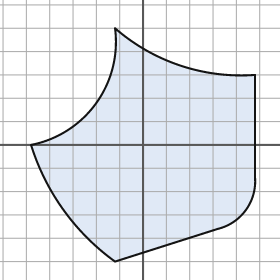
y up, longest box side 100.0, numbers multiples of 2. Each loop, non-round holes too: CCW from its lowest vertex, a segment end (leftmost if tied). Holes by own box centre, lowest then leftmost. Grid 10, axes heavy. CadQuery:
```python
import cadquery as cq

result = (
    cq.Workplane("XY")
    .moveTo(-12.0, -50.0)
    .lineTo(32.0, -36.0)
    .threePointArc((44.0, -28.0), (48.0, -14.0))
    .lineTo(48.0, 30.0)
    .threePointArc((16.0, 34.0), (-12.0, 50.0))
    .threePointArc((-20.0, 18.0), (-48.0, 0.0))
    .threePointArc((-34.0, -28.0), (-12.0, -50.0))
    .close()
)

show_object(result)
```